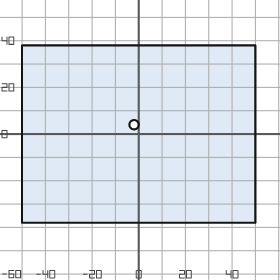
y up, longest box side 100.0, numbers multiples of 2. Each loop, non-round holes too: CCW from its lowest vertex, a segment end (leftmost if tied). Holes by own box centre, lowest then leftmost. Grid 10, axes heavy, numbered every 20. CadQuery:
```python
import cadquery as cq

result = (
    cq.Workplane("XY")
    .moveTo(-50.0, -38.0)
    .lineTo(50.0, -38.0)
    .lineTo(50.0, 38.0)
    .lineTo(-50.0, 38.0)
    .close()
    .moveTo(-2.0, 4.0)
    .circle(2.0)
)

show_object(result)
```